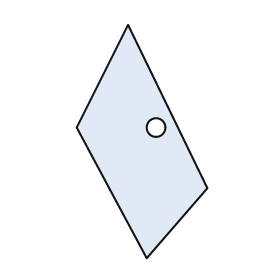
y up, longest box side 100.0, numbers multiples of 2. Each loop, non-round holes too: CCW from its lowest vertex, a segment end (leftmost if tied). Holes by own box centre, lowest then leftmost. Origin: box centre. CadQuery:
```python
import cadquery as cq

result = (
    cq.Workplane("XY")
    .moveTo(2.0, -50.0)
    .lineTo(28.0, -20.0)
    .lineTo(-6.0, 50.0)
    .lineTo(-28.0, 6.0)
    .close()
    .moveTo(6.0, 6.0)
    .circle(4.0)
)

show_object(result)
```